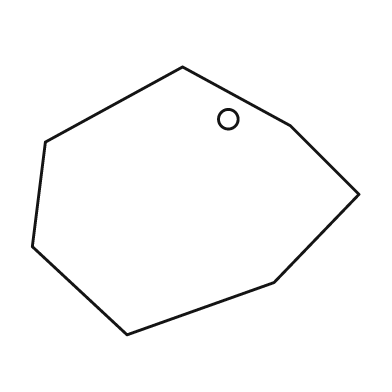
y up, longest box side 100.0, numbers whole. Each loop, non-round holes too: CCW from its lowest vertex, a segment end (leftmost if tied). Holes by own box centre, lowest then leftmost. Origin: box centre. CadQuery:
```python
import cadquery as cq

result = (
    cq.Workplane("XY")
    .moveTo(-21.0, -41.0)
    .lineTo(24.0, -25.0)
    .lineTo(50.0, 2.0)
    .lineTo(29.0, 23.0)
    .lineTo(-4.0, 41.0)
    .lineTo(-46.0, 18.0)
    .lineTo(-50.0, -14.0)
    .close()
    .moveTo(10.0, 25.0)
    .circle(3.0)
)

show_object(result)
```